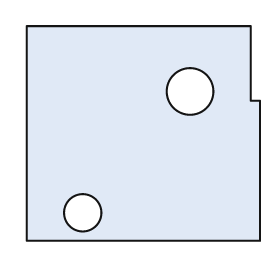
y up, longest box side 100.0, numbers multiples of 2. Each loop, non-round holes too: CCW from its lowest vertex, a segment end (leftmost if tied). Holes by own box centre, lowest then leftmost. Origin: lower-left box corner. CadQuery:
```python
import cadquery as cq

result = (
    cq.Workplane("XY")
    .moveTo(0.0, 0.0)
    .lineTo(100.0, 0.0)
    .lineTo(100.0, 60.0)
    .lineTo(96.0, 60.0)
    .lineTo(96.0, 92.0)
    .lineTo(0.0, 92.0)
    .close()
    .moveTo(24.0, 12.0)
    .circle(8.0)
    .moveTo(70.0, 64.0)
    .circle(10.0)
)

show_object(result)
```